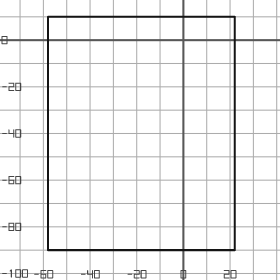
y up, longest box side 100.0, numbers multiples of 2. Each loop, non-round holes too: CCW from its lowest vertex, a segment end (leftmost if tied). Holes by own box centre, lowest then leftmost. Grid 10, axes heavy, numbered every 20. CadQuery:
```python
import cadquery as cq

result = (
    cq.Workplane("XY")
    .moveTo(-58.0, -90.0)
    .lineTo(22.0, -90.0)
    .lineTo(22.0, 10.0)
    .lineTo(-58.0, 10.0)
    .close()
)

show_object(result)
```